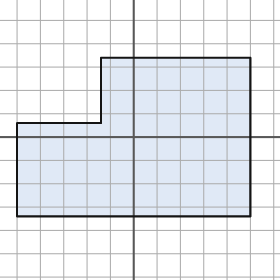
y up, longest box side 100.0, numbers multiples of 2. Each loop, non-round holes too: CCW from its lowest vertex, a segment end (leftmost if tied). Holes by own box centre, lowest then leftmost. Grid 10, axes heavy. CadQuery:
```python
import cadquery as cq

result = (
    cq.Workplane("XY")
    .moveTo(-50.0, -34.0)
    .lineTo(50.0, -34.0)
    .lineTo(50.0, 34.0)
    .lineTo(-14.0, 34.0)
    .lineTo(-14.0, 6.0)
    .lineTo(-50.0, 6.0)
    .close()
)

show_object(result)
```